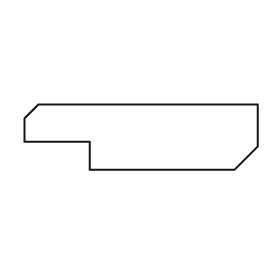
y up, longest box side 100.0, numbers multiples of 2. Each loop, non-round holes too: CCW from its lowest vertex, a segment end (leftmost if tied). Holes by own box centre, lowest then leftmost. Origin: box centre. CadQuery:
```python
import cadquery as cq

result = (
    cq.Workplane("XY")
    .moveTo(-22.0, -14.0)
    .lineTo(40.0, -14.0)
    .lineTo(50.0, -4.0)
    .lineTo(50.0, 14.0)
    .lineTo(-44.0, 14.0)
    .lineTo(-50.0, 8.0)
    .lineTo(-50.0, -2.0)
    .lineTo(-22.0, -2.0)
    .close()
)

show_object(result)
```